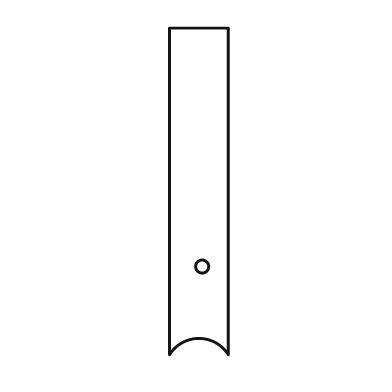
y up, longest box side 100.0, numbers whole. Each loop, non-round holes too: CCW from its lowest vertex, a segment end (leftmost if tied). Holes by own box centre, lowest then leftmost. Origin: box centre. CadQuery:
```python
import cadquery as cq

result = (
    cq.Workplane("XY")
    .moveTo(-9.0, -50.0)
    .threePointArc((0.0, -45.0), (9.0, -50.0))
    .lineTo(9.0, 50.0)
    .lineTo(-9.0, 50.0)
    .close()
    .moveTo(1.0, -23.0)
    .circle(2.0)
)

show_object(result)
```